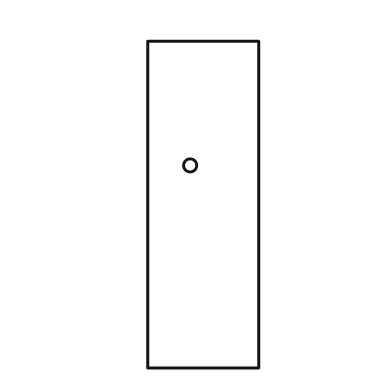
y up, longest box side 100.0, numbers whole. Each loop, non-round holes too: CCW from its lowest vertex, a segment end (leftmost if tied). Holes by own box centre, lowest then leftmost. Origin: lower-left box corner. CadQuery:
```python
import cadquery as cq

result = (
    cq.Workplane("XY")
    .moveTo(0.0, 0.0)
    .lineTo(34.0, 0.0)
    .lineTo(34.0, 100.0)
    .lineTo(0.0, 100.0)
    .close()
    .moveTo(13.0, 62.0)
    .circle(2.0)
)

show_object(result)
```